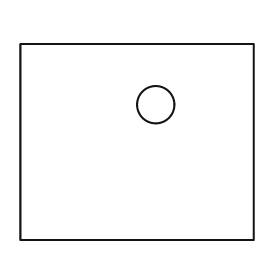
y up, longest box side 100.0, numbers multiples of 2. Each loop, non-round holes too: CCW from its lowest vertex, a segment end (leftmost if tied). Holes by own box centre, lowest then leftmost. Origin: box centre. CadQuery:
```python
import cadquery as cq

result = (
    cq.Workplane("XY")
    .moveTo(-50.0, -42.0)
    .lineTo(50.0, -42.0)
    .lineTo(50.0, 42.0)
    .lineTo(-50.0, 42.0)
    .close()
    .moveTo(8.0, 16.0)
    .circle(8.0)
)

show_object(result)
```